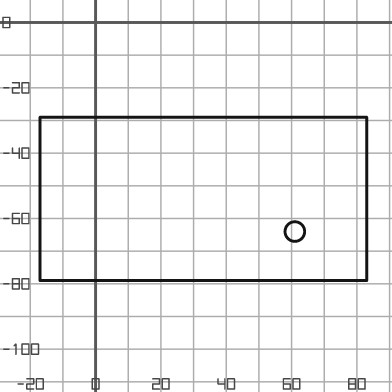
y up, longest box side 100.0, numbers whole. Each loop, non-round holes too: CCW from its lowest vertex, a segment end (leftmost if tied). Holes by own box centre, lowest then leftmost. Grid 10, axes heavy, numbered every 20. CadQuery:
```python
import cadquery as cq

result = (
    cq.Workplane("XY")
    .moveTo(-17.0, -79.0)
    .lineTo(83.0, -79.0)
    .lineTo(83.0, -29.0)
    .lineTo(-17.0, -29.0)
    .close()
    .moveTo(61.0, -64.0)
    .circle(3.0)
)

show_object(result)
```